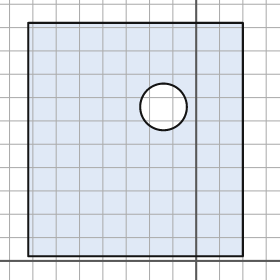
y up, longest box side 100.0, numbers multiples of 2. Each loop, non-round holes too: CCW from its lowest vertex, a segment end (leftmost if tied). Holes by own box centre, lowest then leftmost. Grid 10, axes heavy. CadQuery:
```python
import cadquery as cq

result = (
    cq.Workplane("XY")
    .moveTo(-72.0, 2.0)
    .lineTo(20.0, 2.0)
    .lineTo(20.0, 102.0)
    .lineTo(-72.0, 102.0)
    .close()
    .moveTo(-14.0, 66.0)
    .circle(10.0)
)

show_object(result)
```